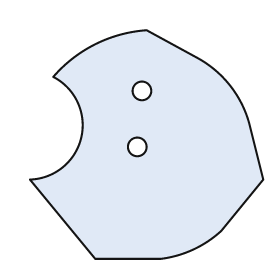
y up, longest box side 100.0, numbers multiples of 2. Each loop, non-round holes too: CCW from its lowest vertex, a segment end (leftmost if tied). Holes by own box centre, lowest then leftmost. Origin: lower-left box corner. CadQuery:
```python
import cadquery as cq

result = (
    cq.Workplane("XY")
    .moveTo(28.0, 0.0)
    .lineTo(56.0, 0.0)
    .threePointArc((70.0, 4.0), (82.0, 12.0))
    .lineTo(100.0, 34.0)
    .lineTo(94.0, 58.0)
    .threePointArc((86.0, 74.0), (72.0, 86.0))
    .lineTo(50.0, 98.0)
    .threePointArc((28.0, 92.0), (10.0, 78.0))
    .threePointArc((22.0, 52.0), (0.0, 34.0))
    .close()
    .moveTo(46.0, 48.0)
    .circle(4.0)
    .moveTo(48.0, 72.0)
    .circle(4.0)
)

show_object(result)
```